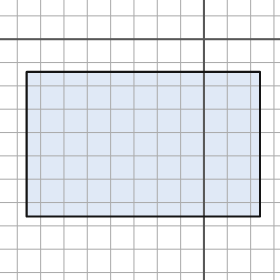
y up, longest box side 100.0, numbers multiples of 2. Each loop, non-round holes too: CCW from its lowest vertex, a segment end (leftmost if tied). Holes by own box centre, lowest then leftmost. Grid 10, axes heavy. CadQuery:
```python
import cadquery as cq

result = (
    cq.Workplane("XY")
    .moveTo(-76.0, -76.0)
    .lineTo(24.0, -76.0)
    .lineTo(24.0, -14.0)
    .lineTo(-76.0, -14.0)
    .close()
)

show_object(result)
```